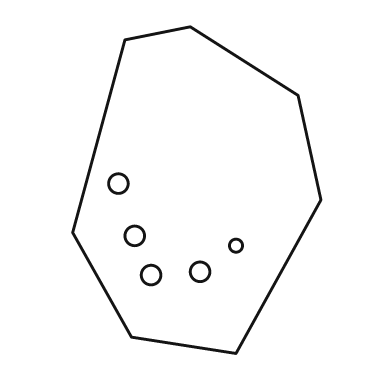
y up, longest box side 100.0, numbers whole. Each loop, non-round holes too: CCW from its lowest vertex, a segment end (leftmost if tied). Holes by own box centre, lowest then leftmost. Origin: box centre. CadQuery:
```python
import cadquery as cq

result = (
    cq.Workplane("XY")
    .moveTo(12.0, -50.0)
    .lineTo(38.0, -3.0)
    .lineTo(31.0, 29.0)
    .lineTo(-2.0, 50.0)
    .lineTo(-22.0, 46.0)
    .lineTo(-38.0, -13.0)
    .lineTo(-20.0, -45.0)
    .close()
    .moveTo(-14.0, -26.0)
    .circle(3.0)
    .moveTo(1.0, -25.0)
    .circle(3.0)
    .moveTo(12.0, -17.0)
    .circle(2.0)
    .moveTo(-19.0, -14.0)
    .circle(3.0)
    .moveTo(-24.0, 2.0)
    .circle(3.0)
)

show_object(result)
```